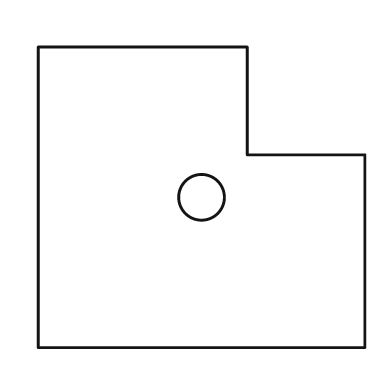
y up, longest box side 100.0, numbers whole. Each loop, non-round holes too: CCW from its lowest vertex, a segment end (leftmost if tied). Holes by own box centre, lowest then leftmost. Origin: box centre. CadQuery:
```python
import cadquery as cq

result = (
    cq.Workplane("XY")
    .moveTo(-50.0, -46.0)
    .lineTo(50.0, -46.0)
    .lineTo(50.0, 13.0)
    .lineTo(14.0, 13.0)
    .lineTo(14.0, 46.0)
    .lineTo(-50.0, 46.0)
    .close()
    .moveTo(0.0, 0.0)
    .circle(7.0)
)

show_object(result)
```